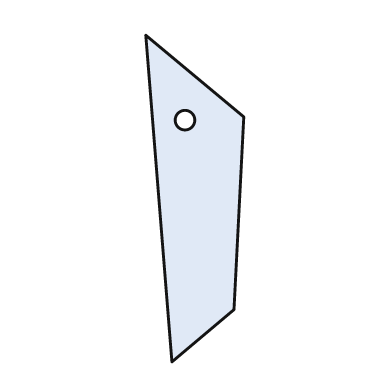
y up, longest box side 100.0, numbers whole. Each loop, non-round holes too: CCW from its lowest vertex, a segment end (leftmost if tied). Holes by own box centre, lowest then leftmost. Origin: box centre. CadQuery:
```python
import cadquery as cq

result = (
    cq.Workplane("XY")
    .moveTo(-7.0, -50.0)
    .lineTo(12.0, -34.0)
    .lineTo(15.0, 25.0)
    .lineTo(-15.0, 50.0)
    .close()
    .moveTo(-3.0, 24.0)
    .circle(3.0)
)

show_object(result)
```